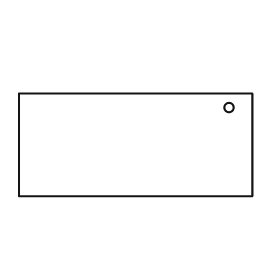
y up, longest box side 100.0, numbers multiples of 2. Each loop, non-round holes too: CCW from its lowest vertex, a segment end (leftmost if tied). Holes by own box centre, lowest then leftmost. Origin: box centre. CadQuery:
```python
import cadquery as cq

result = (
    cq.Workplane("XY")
    .moveTo(-50.0, -22.0)
    .lineTo(50.0, -22.0)
    .lineTo(50.0, 22.0)
    .lineTo(-50.0, 22.0)
    .close()
    .moveTo(40.0, 16.0)
    .circle(2.0)
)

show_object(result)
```